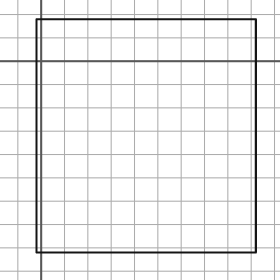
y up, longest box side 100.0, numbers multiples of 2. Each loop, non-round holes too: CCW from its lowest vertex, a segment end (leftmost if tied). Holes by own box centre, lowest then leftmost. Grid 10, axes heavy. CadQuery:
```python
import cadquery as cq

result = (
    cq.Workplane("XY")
    .moveTo(-2.0, -82.0)
    .lineTo(92.0, -82.0)
    .lineTo(92.0, 18.0)
    .lineTo(-2.0, 18.0)
    .close()
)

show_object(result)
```